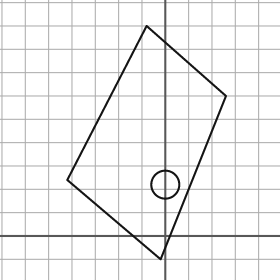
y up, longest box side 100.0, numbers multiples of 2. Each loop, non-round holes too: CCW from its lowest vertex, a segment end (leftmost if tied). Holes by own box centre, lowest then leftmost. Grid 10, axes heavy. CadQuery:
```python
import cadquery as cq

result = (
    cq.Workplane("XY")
    .moveTo(-2.0, -10.0)
    .lineTo(26.0, 60.0)
    .lineTo(-8.0, 90.0)
    .lineTo(-42.0, 24.0)
    .close()
    .moveTo(0.0, 22.0)
    .circle(6.0)
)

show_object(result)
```